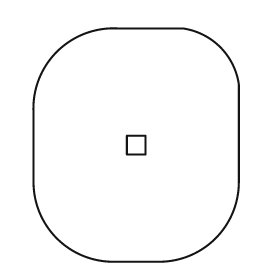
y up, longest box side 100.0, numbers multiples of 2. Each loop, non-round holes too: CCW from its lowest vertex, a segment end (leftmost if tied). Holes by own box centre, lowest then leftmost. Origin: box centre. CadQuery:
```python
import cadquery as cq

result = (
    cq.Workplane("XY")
    .moveTo(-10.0, -50.0)
    .lineTo(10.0, -50.0)
    .threePointArc((34.0, -40.0), (44.0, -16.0))
    .lineTo(44.0, 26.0)
    .threePointArc((36.0, 42.0), (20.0, 50.0))
    .lineTo(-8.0, 50.0)
    .threePointArc((-34.0, 40.0), (-44.0, 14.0))
    .lineTo(-44.0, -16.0)
    .threePointArc((-34.0, -40.0), (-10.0, -50.0))
    .close()
    .moveTo(-4.0, -4.0)
    .lineTo(4.0, -4.0)
    .lineTo(4.0, 4.0)
    .lineTo(-4.0, 4.0)
    .close()
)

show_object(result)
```